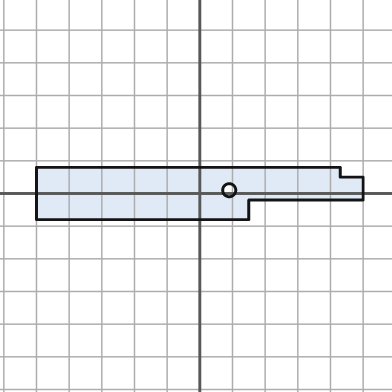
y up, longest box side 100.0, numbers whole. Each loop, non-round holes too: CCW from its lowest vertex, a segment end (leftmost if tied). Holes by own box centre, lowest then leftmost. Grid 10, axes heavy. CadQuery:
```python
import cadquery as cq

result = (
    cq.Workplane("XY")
    .moveTo(-50.0, -8.0)
    .lineTo(15.0, -8.0)
    .lineTo(15.0, -2.0)
    .lineTo(50.0, -2.0)
    .lineTo(50.0, 5.0)
    .lineTo(43.0, 5.0)
    .lineTo(43.0, 8.0)
    .lineTo(-50.0, 8.0)
    .close()
    .moveTo(9.0, 1.0)
    .circle(2.0)
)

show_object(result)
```